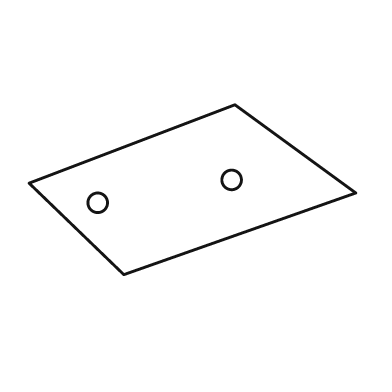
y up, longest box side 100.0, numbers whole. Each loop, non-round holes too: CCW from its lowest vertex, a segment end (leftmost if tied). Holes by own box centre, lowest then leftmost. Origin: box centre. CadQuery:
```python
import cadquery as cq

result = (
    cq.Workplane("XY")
    .moveTo(-21.0, -26.0)
    .lineTo(50.0, -1.0)
    .lineTo(13.0, 26.0)
    .lineTo(-50.0, 2.0)
    .close()
    .moveTo(-29.0, -4.0)
    .circle(3.0)
    .moveTo(12.0, 3.0)
    .circle(3.0)
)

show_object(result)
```